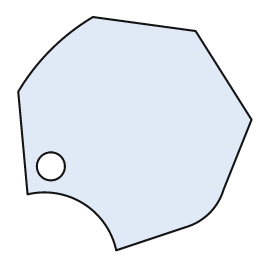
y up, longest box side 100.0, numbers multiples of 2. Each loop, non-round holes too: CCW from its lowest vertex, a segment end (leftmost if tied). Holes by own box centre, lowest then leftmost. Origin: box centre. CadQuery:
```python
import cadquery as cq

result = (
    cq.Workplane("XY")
    .moveTo(-8.0, -50.0)
    .lineTo(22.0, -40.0)
    .threePointArc((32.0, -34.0), (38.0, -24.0))
    .lineTo(50.0, 6.0)
    .lineTo(26.0, 44.0)
    .lineTo(-18.0, 50.0)
    .threePointArc((-36.0, 36.0), (-50.0, 18.0))
    .lineTo(-46.0, -26.0)
    .threePointArc((-22.0, -30.0), (-8.0, -50.0))
    .close()
    .moveTo(-36.0, -14.0)
    .circle(6.0)
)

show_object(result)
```